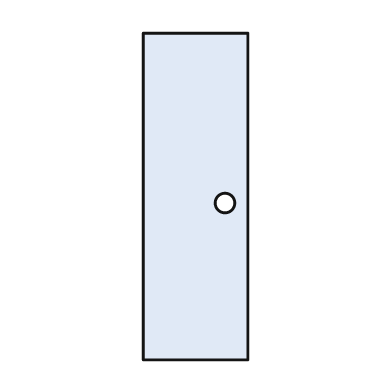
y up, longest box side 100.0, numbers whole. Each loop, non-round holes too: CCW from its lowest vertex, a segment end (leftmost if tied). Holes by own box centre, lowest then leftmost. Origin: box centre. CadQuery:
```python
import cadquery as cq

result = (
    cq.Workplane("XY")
    .moveTo(-16.0, -50.0)
    .lineTo(16.0, -50.0)
    .lineTo(16.0, 50.0)
    .lineTo(-16.0, 50.0)
    .close()
    .moveTo(9.0, -2.0)
    .circle(3.0)
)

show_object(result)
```